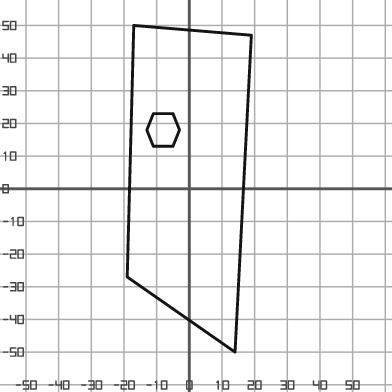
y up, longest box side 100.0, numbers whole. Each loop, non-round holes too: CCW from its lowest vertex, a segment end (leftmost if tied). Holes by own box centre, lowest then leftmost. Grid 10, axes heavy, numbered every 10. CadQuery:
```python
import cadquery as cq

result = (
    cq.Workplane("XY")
    .moveTo(14.0, -50.0)
    .lineTo(19.0, 47.0)
    .lineTo(-17.0, 50.0)
    .lineTo(-19.0, -27.0)
    .close()
    .moveTo(-11.0, 13.0)
    .lineTo(-5.0, 13.0)
    .lineTo(-3.0, 18.0)
    .lineTo(-5.0, 23.0)
    .lineTo(-11.0, 23.0)
    .lineTo(-13.0, 18.0)
    .close()
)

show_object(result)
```